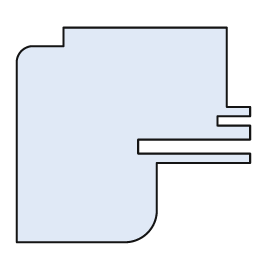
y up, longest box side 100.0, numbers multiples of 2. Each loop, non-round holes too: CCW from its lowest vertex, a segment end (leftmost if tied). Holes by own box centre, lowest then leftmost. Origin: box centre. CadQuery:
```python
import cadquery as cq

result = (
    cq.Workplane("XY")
    .moveTo(-50.0, -46.0)
    .lineTo(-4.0, -46.0)
    .threePointArc((6.0, -42.0), (10.0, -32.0))
    .lineTo(10.0, -12.0)
    .lineTo(50.0, -12.0)
    .lineTo(50.0, -8.0)
    .lineTo(2.0, -8.0)
    .lineTo(2.0, -2.0)
    .lineTo(50.0, -2.0)
    .lineTo(50.0, 4.0)
    .lineTo(36.0, 4.0)
    .lineTo(36.0, 8.0)
    .lineTo(50.0, 8.0)
    .lineTo(50.0, 12.0)
    .lineTo(40.0, 12.0)
    .lineTo(40.0, 46.0)
    .lineTo(-30.0, 46.0)
    .lineTo(-30.0, 38.0)
    .lineTo(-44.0, 38.0)
    .threePointArc((-48.0, 36.0), (-50.0, 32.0))
    .close()
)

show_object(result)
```